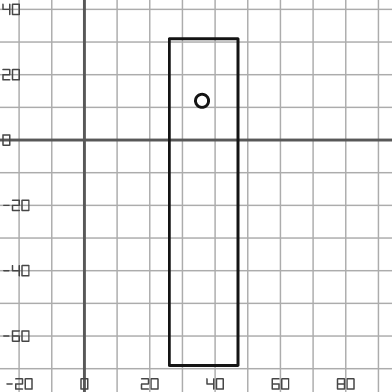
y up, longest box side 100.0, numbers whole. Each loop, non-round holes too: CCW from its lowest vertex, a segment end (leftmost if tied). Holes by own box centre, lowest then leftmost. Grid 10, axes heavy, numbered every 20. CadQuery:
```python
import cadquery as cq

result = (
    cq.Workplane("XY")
    .moveTo(26.0, -69.0)
    .lineTo(47.0, -69.0)
    .lineTo(47.0, 31.0)
    .lineTo(26.0, 31.0)
    .close()
    .moveTo(36.0, 12.0)
    .circle(2.0)
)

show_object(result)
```